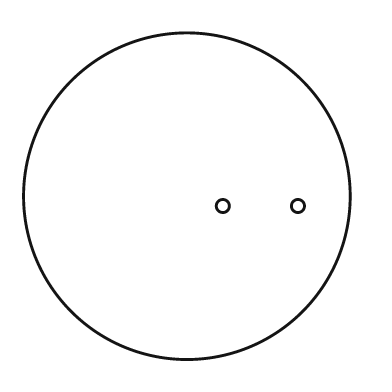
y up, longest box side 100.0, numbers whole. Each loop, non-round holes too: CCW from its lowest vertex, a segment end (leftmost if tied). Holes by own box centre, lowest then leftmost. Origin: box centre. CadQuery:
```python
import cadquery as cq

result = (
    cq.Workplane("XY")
    .moveTo(0.0, 0.0)
    .circle(50.0)
    .moveTo(11.0, -3.0)
    .circle(2.0)
    .moveTo(34.0, -3.0)
    .circle(2.0)
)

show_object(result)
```